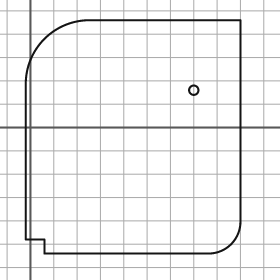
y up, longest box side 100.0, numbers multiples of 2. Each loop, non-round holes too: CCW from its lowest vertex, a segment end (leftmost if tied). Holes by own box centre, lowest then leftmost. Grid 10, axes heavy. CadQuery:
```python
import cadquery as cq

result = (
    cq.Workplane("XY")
    .moveTo(6.0, -54.0)
    .lineTo(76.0, -54.0)
    .threePointArc((86.0, -50.0), (90.0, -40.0))
    .lineTo(90.0, 46.0)
    .lineTo(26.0, 46.0)
    .threePointArc((6.0, 38.0), (-2.0, 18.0))
    .lineTo(-2.0, -48.0)
    .lineTo(6.0, -48.0)
    .close()
    .moveTo(70.0, 16.0)
    .circle(2.0)
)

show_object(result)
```